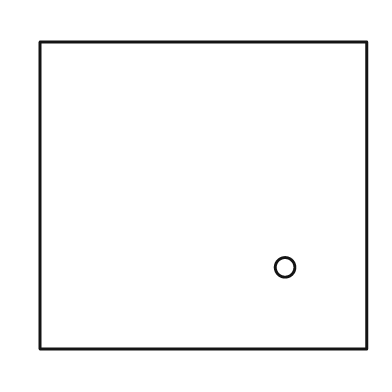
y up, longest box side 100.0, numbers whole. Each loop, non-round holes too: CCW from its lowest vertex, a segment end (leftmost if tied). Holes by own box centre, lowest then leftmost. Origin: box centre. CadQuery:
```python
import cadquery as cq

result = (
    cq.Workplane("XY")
    .moveTo(-50.0, -47.0)
    .lineTo(50.0, -47.0)
    .lineTo(50.0, 47.0)
    .lineTo(-50.0, 47.0)
    .close()
    .moveTo(25.0, -22.0)
    .circle(3.0)
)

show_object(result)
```